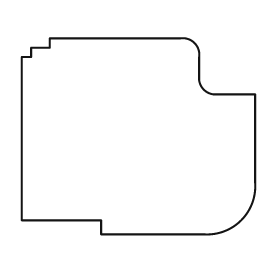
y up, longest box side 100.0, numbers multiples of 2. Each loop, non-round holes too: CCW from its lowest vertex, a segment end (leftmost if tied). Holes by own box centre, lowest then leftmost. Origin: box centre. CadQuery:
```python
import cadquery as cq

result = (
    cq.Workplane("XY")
    .moveTo(-16.0, -42.0)
    .lineTo(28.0, -42.0)
    .threePointArc((44.0, -36.0), (50.0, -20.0))
    .lineTo(50.0, 18.0)
    .lineTo(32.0, 18.0)
    .threePointArc((28.0, 20.0), (26.0, 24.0))
    .lineTo(26.0, 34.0)
    .threePointArc((24.0, 40.0), (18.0, 42.0))
    .lineTo(-38.0, 42.0)
    .lineTo(-38.0, 38.0)
    .lineTo(-46.0, 38.0)
    .lineTo(-46.0, 34.0)
    .lineTo(-50.0, 34.0)
    .lineTo(-50.0, -36.0)
    .lineTo(-16.0, -36.0)
    .close()
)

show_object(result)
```